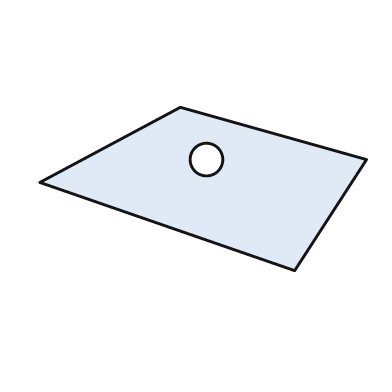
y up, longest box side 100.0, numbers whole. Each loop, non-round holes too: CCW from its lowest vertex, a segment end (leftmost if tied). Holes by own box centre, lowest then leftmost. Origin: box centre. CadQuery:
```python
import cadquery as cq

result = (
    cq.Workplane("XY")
    .moveTo(28.0, -25.0)
    .lineTo(50.0, 9.0)
    .lineTo(-7.0, 25.0)
    .lineTo(-50.0, 2.0)
    .close()
    .moveTo(1.0, 9.0)
    .circle(5.0)
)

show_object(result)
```